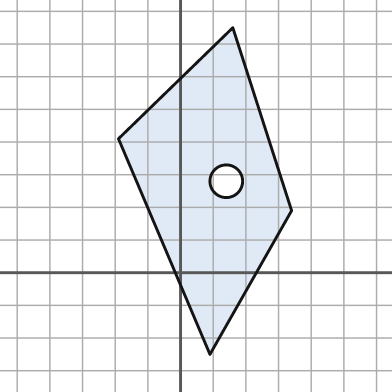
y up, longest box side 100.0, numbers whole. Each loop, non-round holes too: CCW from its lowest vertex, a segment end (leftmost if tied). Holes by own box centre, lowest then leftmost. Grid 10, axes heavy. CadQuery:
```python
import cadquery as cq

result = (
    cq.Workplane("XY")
    .moveTo(9.0, -25.0)
    .lineTo(34.0, 19.0)
    .lineTo(16.0, 75.0)
    .lineTo(-19.0, 41.0)
    .close()
    .moveTo(14.0, 28.0)
    .circle(5.0)
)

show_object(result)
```